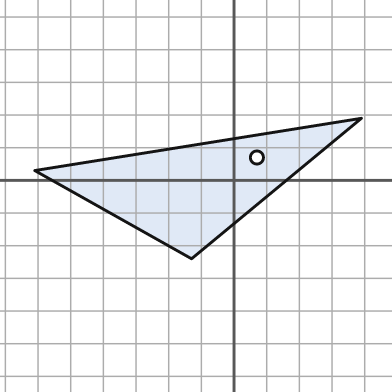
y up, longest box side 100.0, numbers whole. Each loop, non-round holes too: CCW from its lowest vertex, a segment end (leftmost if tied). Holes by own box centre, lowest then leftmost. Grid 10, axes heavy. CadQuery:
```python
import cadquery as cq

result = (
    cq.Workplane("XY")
    .moveTo(-13.0, -24.0)
    .lineTo(39.0, 19.0)
    .lineTo(-61.0, 3.0)
    .close()
    .moveTo(7.0, 7.0)
    .circle(2.0)
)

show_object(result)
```